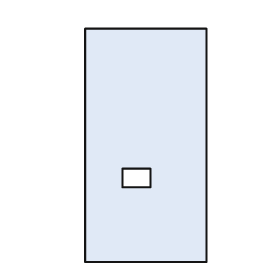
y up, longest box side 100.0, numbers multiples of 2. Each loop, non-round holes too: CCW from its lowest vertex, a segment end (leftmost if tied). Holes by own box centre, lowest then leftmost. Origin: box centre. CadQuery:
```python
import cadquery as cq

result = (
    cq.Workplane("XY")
    .moveTo(-26.0, -50.0)
    .lineTo(26.0, -50.0)
    .lineTo(26.0, 50.0)
    .lineTo(-26.0, 50.0)
    .close()
    .moveTo(-10.0, -18.0)
    .lineTo(2.0, -18.0)
    .lineTo(2.0, -10.0)
    .lineTo(-10.0, -10.0)
    .close()
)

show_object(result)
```